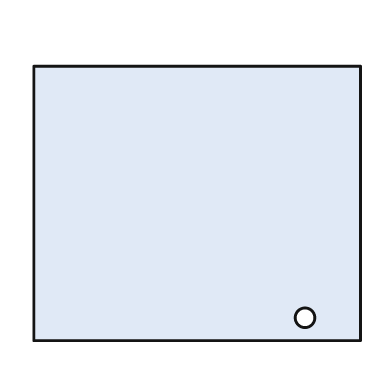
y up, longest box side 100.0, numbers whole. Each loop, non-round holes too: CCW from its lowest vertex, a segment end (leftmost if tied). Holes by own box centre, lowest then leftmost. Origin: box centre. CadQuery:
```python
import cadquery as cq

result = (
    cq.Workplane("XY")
    .moveTo(-50.0, -42.0)
    .lineTo(50.0, -42.0)
    .lineTo(50.0, 42.0)
    .lineTo(-50.0, 42.0)
    .close()
    .moveTo(33.0, -35.0)
    .circle(3.0)
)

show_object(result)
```